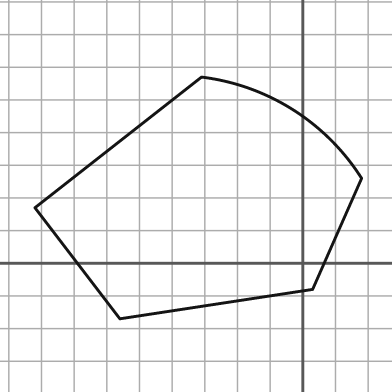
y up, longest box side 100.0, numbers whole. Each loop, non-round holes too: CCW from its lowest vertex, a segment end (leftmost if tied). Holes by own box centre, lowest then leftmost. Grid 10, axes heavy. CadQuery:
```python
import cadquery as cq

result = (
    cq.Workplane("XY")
    .moveTo(-56.0, -17.0)
    .lineTo(3.0, -8.0)
    .lineTo(18.0, 26.0)
    .threePointArc((-3.0, 47.0), (-31.0, 57.0))
    .lineTo(-82.0, 17.0)
    .close()
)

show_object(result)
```